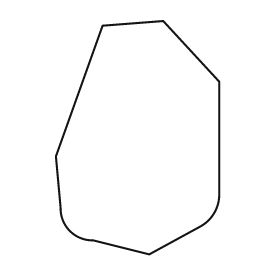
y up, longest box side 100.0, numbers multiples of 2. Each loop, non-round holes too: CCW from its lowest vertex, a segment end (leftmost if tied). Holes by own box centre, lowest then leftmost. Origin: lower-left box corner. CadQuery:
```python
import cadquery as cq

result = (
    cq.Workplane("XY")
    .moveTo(40.0, 0.0)
    .lineTo(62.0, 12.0)
    .threePointArc((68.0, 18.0), (70.0, 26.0))
    .lineTo(70.0, 74.0)
    .lineTo(46.0, 100.0)
    .lineTo(20.0, 98.0)
    .lineTo(0.0, 42.0)
    .lineTo(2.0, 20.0)
    .threePointArc((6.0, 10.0), (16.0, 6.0))
    .close()
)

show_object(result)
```